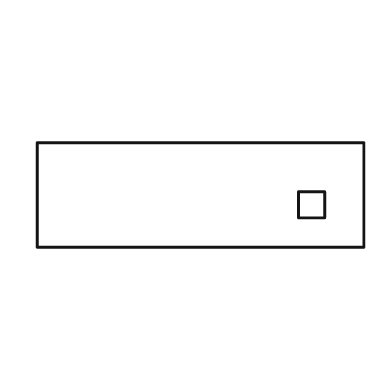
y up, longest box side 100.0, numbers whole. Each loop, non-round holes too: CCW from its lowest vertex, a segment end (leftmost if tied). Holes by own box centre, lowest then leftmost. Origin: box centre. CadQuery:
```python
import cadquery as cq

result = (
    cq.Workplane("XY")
    .moveTo(-50.0, -16.0)
    .lineTo(50.0, -16.0)
    .lineTo(50.0, 16.0)
    .lineTo(-50.0, 16.0)
    .close()
    .moveTo(30.0, -7.0)
    .lineTo(38.0, -7.0)
    .lineTo(38.0, 1.0)
    .lineTo(30.0, 1.0)
    .close()
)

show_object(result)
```